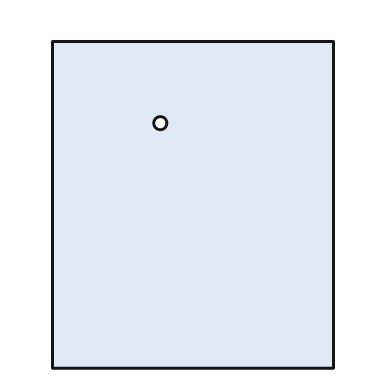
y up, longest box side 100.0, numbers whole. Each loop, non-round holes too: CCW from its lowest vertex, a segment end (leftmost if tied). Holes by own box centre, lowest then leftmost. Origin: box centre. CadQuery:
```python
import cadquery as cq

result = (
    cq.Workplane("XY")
    .moveTo(-43.0, -50.0)
    .lineTo(43.0, -50.0)
    .lineTo(43.0, 50.0)
    .lineTo(-43.0, 50.0)
    .close()
    .moveTo(-10.0, 25.0)
    .circle(2.0)
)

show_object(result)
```